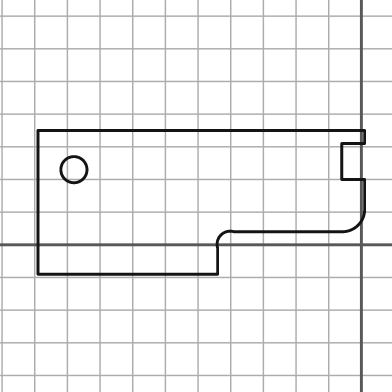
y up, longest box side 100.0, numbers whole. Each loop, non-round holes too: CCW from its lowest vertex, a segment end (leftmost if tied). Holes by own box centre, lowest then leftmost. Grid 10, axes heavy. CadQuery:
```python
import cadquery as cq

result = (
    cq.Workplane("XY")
    .moveTo(-99.0, -9.0)
    .lineTo(-44.0, -9.0)
    .lineTo(-44.0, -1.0)
    .threePointArc((-43.0, 3.0), (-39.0, 4.0))
    .lineTo(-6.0, 4.0)
    .threePointArc((-1.0, 6.0), (1.0, 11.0))
    .lineTo(1.0, 20.0)
    .lineTo(-6.0, 20.0)
    .lineTo(-6.0, 31.0)
    .lineTo(1.0, 31.0)
    .lineTo(1.0, 35.0)
    .lineTo(-99.0, 35.0)
    .close()
    .moveTo(-88.0, 23.0)
    .circle(4.0)
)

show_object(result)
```